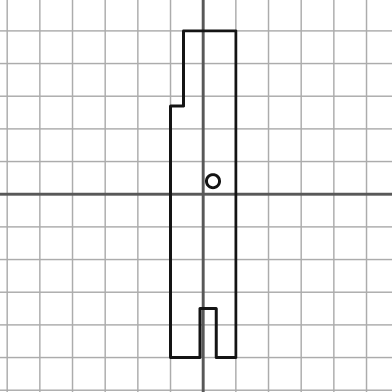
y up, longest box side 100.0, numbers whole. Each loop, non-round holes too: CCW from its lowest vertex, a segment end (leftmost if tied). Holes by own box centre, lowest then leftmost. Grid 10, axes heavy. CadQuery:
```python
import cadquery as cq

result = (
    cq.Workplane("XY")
    .moveTo(-10.0, -50.0)
    .lineTo(-1.0, -50.0)
    .lineTo(-1.0, -35.0)
    .lineTo(4.0, -35.0)
    .lineTo(4.0, -50.0)
    .lineTo(10.0, -50.0)
    .lineTo(10.0, 50.0)
    .lineTo(-6.0, 50.0)
    .lineTo(-6.0, 27.0)
    .lineTo(-10.0, 27.0)
    .close()
    .moveTo(3.0, 4.0)
    .circle(2.0)
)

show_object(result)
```